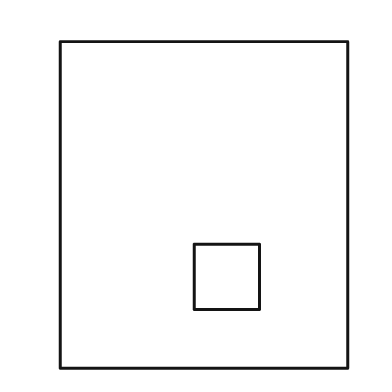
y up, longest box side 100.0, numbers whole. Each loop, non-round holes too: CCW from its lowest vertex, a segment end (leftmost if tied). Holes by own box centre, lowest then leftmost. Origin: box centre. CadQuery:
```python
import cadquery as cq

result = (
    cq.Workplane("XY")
    .moveTo(-44.0, -50.0)
    .lineTo(44.0, -50.0)
    .lineTo(44.0, 50.0)
    .lineTo(-44.0, 50.0)
    .close()
    .moveTo(-3.0, -32.0)
    .lineTo(17.0, -32.0)
    .lineTo(17.0, -12.0)
    .lineTo(-3.0, -12.0)
    .close()
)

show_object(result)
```